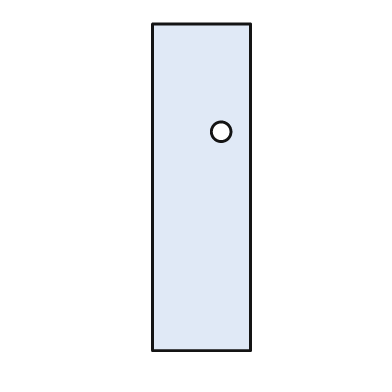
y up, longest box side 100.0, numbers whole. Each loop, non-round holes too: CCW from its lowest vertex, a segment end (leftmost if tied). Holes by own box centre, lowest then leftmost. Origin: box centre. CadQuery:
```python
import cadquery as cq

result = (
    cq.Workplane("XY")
    .moveTo(-15.0, -50.0)
    .lineTo(15.0, -50.0)
    .lineTo(15.0, 50.0)
    .lineTo(-15.0, 50.0)
    .close()
    .moveTo(6.0, 17.0)
    .circle(3.0)
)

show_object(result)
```